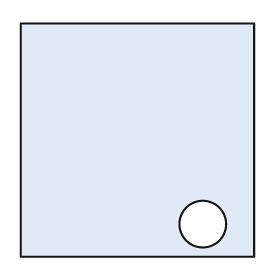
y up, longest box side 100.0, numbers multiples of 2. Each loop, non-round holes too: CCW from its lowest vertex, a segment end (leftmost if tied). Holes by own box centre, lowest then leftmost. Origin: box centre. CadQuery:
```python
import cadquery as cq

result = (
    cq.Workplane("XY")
    .moveTo(-50.0, -50.0)
    .lineTo(50.0, -50.0)
    .lineTo(50.0, 50.0)
    .lineTo(-50.0, 50.0)
    .close()
    .moveTo(28.0, -36.0)
    .circle(10.0)
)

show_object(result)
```